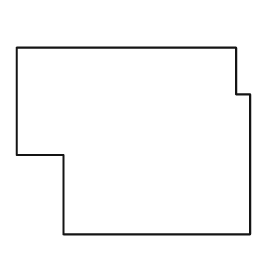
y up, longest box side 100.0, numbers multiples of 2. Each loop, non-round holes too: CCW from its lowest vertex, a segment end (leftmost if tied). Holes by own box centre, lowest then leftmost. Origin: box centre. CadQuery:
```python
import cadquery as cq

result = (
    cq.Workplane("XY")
    .moveTo(-30.0, -40.0)
    .lineTo(50.0, -40.0)
    .lineTo(50.0, 20.0)
    .lineTo(44.0, 20.0)
    .lineTo(44.0, 40.0)
    .lineTo(-50.0, 40.0)
    .lineTo(-50.0, -6.0)
    .lineTo(-30.0, -6.0)
    .close()
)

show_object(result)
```